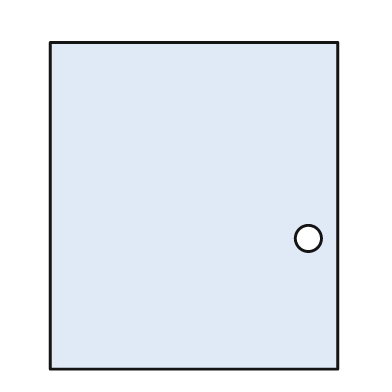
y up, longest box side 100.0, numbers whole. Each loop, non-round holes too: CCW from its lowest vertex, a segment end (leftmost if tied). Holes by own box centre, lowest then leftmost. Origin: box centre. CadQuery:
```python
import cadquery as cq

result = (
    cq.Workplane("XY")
    .moveTo(-44.0, -50.0)
    .lineTo(44.0, -50.0)
    .lineTo(44.0, 50.0)
    .lineTo(-44.0, 50.0)
    .close()
    .moveTo(35.0, -10.0)
    .circle(4.0)
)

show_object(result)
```